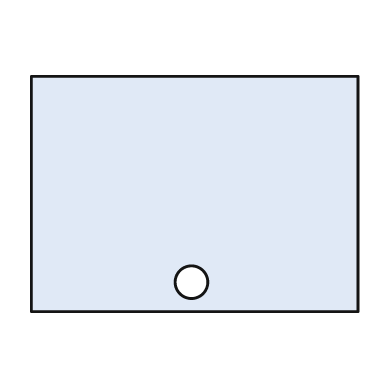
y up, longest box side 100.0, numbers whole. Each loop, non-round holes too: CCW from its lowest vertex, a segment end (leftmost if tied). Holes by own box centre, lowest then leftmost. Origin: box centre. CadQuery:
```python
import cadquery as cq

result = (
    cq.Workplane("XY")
    .moveTo(-50.0, -36.0)
    .lineTo(50.0, -36.0)
    .lineTo(50.0, 36.0)
    .lineTo(-50.0, 36.0)
    .close()
    .moveTo(-1.0, -27.0)
    .circle(5.0)
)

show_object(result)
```